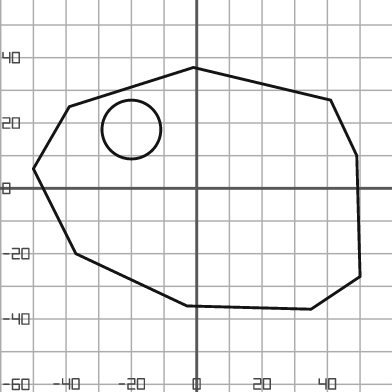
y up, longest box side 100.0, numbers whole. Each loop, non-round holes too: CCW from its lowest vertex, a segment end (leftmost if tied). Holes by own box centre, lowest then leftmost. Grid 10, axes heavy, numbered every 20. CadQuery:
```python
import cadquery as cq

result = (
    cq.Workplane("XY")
    .moveTo(35.0, -37.0)
    .lineTo(50.0, -27.0)
    .lineTo(49.0, 10.0)
    .lineTo(41.0, 27.0)
    .lineTo(-1.0, 37.0)
    .lineTo(-39.0, 25.0)
    .lineTo(-50.0, 6.0)
    .lineTo(-37.0, -20.0)
    .lineTo(-3.0, -36.0)
    .close()
    .moveTo(-20.0, 18.0)
    .circle(9.0)
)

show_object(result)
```